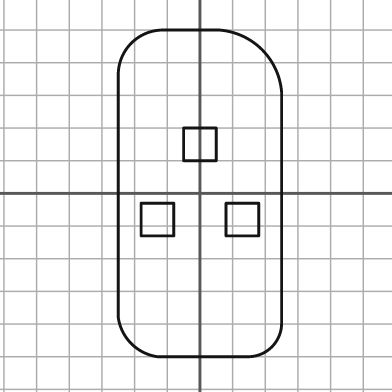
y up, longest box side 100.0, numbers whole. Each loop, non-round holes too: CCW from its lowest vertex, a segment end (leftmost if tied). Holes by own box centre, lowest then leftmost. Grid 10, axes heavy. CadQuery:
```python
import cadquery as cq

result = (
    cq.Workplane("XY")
    .moveTo(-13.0, -50.0)
    .lineTo(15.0, -50.0)
    .threePointArc((22.0, -47.0), (25.0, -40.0))
    .lineTo(25.0, 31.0)
    .threePointArc((19.0, 44.0), (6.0, 50.0))
    .lineTo(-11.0, 50.0)
    .threePointArc((-21.0, 46.0), (-25.0, 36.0))
    .lineTo(-25.0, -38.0)
    .threePointArc((-21.0, -46.0), (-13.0, -50.0))
    .close()
    .moveTo(-18.0, -13.0)
    .lineTo(-8.0, -13.0)
    .lineTo(-8.0, -3.0)
    .lineTo(-18.0, -3.0)
    .close()
    .moveTo(8.0, -13.0)
    .lineTo(18.0, -13.0)
    .lineTo(18.0, -3.0)
    .lineTo(8.0, -3.0)
    .close()
    .moveTo(-5.0, 10.0)
    .lineTo(5.0, 10.0)
    .lineTo(5.0, 20.0)
    .lineTo(-5.0, 20.0)
    .close()
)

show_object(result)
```